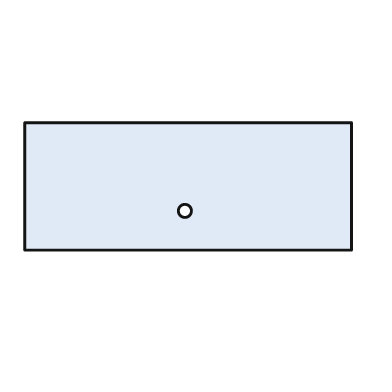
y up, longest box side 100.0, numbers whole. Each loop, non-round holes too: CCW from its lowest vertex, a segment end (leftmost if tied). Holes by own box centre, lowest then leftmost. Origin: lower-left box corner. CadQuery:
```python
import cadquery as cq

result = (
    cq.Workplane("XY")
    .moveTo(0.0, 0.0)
    .lineTo(100.0, 0.0)
    .lineTo(100.0, 39.0)
    .lineTo(0.0, 39.0)
    .close()
    .moveTo(49.0, 12.0)
    .circle(2.0)
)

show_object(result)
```